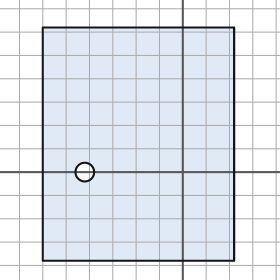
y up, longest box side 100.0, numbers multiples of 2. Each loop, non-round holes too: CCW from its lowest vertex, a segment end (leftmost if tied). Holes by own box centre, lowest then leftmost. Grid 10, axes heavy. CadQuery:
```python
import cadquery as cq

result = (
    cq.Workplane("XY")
    .moveTo(-60.0, -38.0)
    .lineTo(22.0, -38.0)
    .lineTo(22.0, 62.0)
    .lineTo(-60.0, 62.0)
    .close()
    .moveTo(-42.0, 0.0)
    .circle(4.0)
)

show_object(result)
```